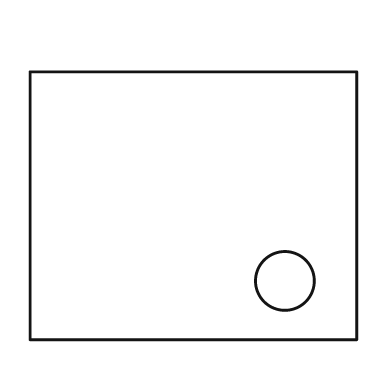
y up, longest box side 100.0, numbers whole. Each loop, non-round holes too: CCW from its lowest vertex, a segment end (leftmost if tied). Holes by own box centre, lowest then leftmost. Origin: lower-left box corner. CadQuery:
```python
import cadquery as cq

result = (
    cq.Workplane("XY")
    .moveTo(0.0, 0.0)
    .lineTo(100.0, 0.0)
    .lineTo(100.0, 82.0)
    .lineTo(0.0, 82.0)
    .close()
    .moveTo(78.0, 18.0)
    .circle(9.0)
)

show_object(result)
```